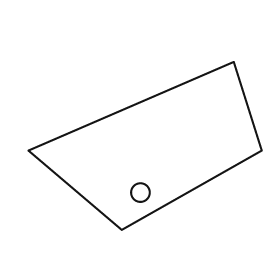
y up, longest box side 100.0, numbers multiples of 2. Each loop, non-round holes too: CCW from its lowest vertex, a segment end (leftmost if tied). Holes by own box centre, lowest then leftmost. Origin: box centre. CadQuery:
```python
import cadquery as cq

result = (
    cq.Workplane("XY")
    .moveTo(-10.0, -36.0)
    .lineTo(50.0, -2.0)
    .lineTo(38.0, 36.0)
    .lineTo(-50.0, -2.0)
    .close()
    .moveTo(-2.0, -20.0)
    .circle(4.0)
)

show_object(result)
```